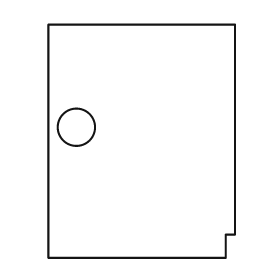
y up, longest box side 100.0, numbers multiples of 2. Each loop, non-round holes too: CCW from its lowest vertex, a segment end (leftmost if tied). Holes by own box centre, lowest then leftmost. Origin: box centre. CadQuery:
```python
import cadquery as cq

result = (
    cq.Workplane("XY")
    .moveTo(-40.0, -50.0)
    .lineTo(36.0, -50.0)
    .lineTo(36.0, -40.0)
    .lineTo(40.0, -40.0)
    .lineTo(40.0, 50.0)
    .lineTo(-40.0, 50.0)
    .close()
    .moveTo(-28.0, 6.0)
    .circle(8.0)
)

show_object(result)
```